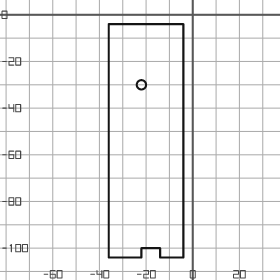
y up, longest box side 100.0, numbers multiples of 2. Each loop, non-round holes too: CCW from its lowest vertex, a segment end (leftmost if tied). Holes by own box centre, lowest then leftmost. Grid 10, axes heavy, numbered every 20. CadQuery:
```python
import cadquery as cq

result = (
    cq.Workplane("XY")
    .moveTo(-36.0, -104.0)
    .lineTo(-22.0, -104.0)
    .lineTo(-22.0, -100.0)
    .lineTo(-14.0, -100.0)
    .lineTo(-14.0, -104.0)
    .lineTo(-4.0, -104.0)
    .lineTo(-4.0, -4.0)
    .lineTo(-36.0, -4.0)
    .close()
    .moveTo(-22.0, -30.0)
    .circle(2.0)
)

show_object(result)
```